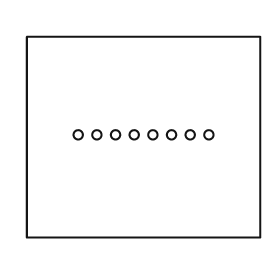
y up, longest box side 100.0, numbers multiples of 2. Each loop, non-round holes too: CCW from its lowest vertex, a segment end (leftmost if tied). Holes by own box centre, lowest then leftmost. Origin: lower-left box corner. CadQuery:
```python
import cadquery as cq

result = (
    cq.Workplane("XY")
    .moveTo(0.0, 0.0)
    .lineTo(100.0, 0.0)
    .lineTo(100.0, 86.0)
    .lineTo(0.0, 86.0)
    .close()
    .moveTo(22.0, 44.0)
    .circle(2.0)
    .moveTo(30.0, 44.0)
    .circle(2.0)
    .moveTo(38.0, 44.0)
    .circle(2.0)
    .moveTo(46.0, 44.0)
    .circle(2.0)
    .moveTo(54.0, 44.0)
    .circle(2.0)
    .moveTo(62.0, 44.0)
    .circle(2.0)
    .moveTo(70.0, 44.0)
    .circle(2.0)
    .moveTo(78.0, 44.0)
    .circle(2.0)
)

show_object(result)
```